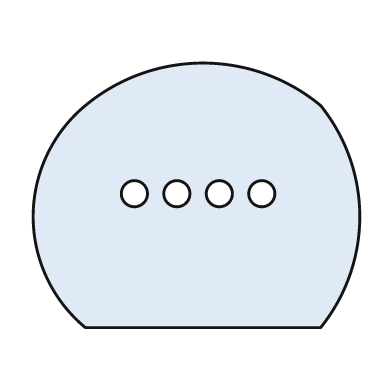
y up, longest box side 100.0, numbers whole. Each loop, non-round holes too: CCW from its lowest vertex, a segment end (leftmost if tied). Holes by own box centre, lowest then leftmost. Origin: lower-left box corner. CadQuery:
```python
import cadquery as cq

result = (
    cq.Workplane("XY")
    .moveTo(16.0, 0.0)
    .lineTo(88.0, 0.0)
    .threePointArc((100.0, 34.0), (88.0, 68.0))
    .threePointArc((52.0, 81.0), (16.0, 68.0))
    .threePointArc((0.0, 34.0), (16.0, 0.0))
    .close()
    .moveTo(31.0, 41.0)
    .circle(4.0)
    .moveTo(44.0, 41.0)
    .circle(4.0)
    .moveTo(57.0, 41.0)
    .circle(4.0)
    .moveTo(70.0, 41.0)
    .circle(4.0)
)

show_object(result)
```